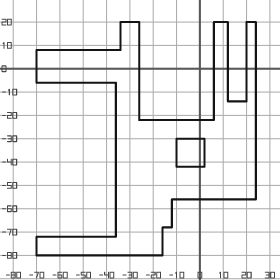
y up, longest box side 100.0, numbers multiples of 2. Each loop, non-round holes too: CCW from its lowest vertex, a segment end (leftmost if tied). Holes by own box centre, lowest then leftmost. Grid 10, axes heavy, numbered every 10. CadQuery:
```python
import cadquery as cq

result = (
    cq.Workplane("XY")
    .moveTo(-70.0, -80.0)
    .lineTo(-16.0, -80.0)
    .lineTo(-16.0, -68.0)
    .lineTo(-12.0, -68.0)
    .lineTo(-12.0, -56.0)
    .lineTo(24.0, -56.0)
    .lineTo(24.0, 20.0)
    .lineTo(20.0, 20.0)
    .lineTo(20.0, -14.0)
    .lineTo(12.0, -14.0)
    .lineTo(12.0, 20.0)
    .lineTo(6.0, 20.0)
    .lineTo(6.0, -22.0)
    .lineTo(-26.0, -22.0)
    .lineTo(-26.0, 20.0)
    .lineTo(-34.0, 20.0)
    .lineTo(-34.0, 8.0)
    .lineTo(-70.0, 8.0)
    .lineTo(-70.0, -6.0)
    .lineTo(-36.0, -6.0)
    .lineTo(-36.0, -72.0)
    .lineTo(-70.0, -72.0)
    .close()
    .moveTo(-10.0, -42.0)
    .lineTo(2.0, -42.0)
    .lineTo(2.0, -30.0)
    .lineTo(-10.0, -30.0)
    .close()
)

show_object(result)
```